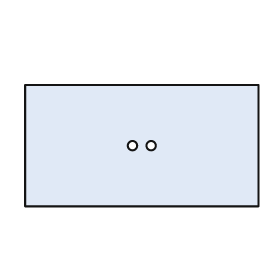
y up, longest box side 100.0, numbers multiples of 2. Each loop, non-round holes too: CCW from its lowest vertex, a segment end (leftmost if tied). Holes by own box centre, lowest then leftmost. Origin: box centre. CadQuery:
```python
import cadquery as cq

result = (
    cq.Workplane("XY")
    .moveTo(-50.0, -26.0)
    .lineTo(50.0, -26.0)
    .lineTo(50.0, 26.0)
    .lineTo(-50.0, 26.0)
    .close()
    .moveTo(-4.0, 0.0)
    .circle(2.0)
    .moveTo(4.0, 0.0)
    .circle(2.0)
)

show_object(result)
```